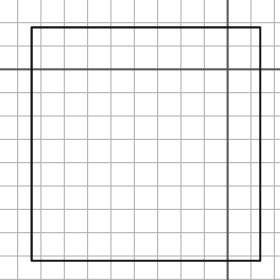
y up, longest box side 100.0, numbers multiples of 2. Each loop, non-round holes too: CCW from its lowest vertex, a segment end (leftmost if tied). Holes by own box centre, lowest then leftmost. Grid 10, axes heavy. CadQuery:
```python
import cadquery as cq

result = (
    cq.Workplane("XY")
    .moveTo(-84.0, -82.0)
    .lineTo(14.0, -82.0)
    .lineTo(14.0, 18.0)
    .lineTo(-84.0, 18.0)
    .close()
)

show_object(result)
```